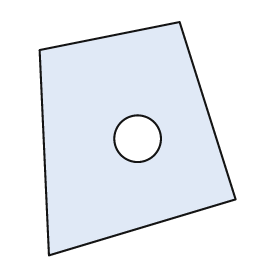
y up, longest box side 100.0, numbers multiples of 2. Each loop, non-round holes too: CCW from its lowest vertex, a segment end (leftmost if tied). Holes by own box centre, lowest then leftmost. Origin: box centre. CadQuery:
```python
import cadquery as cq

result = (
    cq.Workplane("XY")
    .moveTo(-38.0, -50.0)
    .lineTo(42.0, -26.0)
    .lineTo(18.0, 50.0)
    .lineTo(-42.0, 38.0)
    .close()
    .moveTo(0.0, 0.0)
    .circle(10.0)
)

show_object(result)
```